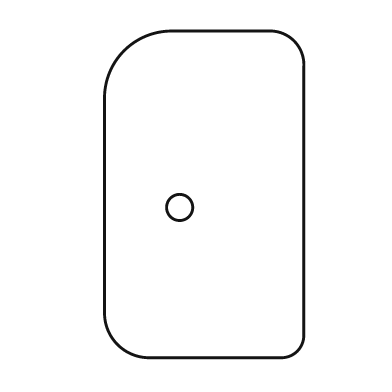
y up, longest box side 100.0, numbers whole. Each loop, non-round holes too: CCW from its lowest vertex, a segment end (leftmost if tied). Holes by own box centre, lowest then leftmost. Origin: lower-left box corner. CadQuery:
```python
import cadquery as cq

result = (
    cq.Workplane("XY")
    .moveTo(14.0, 0.0)
    .lineTo(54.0, 0.0)
    .threePointArc((59.0, 2.0), (61.0, 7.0))
    .lineTo(61.0, 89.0)
    .threePointArc((58.0, 97.0), (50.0, 100.0))
    .lineTo(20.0, 100.0)
    .threePointArc((6.0, 94.0), (0.0, 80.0))
    .lineTo(0.0, 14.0)
    .threePointArc((4.0, 4.0), (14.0, 0.0))
    .close()
    .moveTo(23.0, 46.0)
    .circle(4.0)
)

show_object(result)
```